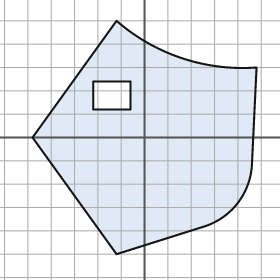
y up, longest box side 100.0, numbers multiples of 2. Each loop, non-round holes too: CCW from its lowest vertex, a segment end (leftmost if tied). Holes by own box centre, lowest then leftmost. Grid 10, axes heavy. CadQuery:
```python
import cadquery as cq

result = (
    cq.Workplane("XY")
    .moveTo(-12.0, -50.0)
    .lineTo(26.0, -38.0)
    .threePointArc((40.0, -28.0), (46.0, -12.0))
    .lineTo(48.0, 30.0)
    .threePointArc((16.0, 34.0), (-12.0, 50.0))
    .lineTo(-48.0, 0.0)
    .close()
    .moveTo(-22.0, 12.0)
    .lineTo(-6.0, 12.0)
    .lineTo(-6.0, 24.0)
    .lineTo(-22.0, 24.0)
    .close()
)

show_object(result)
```